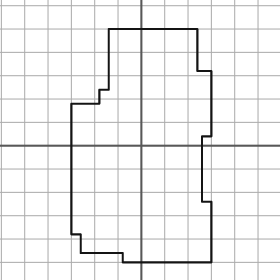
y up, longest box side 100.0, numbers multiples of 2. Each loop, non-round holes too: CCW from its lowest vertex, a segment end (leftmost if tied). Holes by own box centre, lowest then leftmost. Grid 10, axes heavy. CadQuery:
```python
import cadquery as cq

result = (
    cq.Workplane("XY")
    .moveTo(-8.0, -50.0)
    .lineTo(30.0, -50.0)
    .lineTo(30.0, -24.0)
    .lineTo(26.0, -24.0)
    .lineTo(26.0, 4.0)
    .lineTo(30.0, 4.0)
    .lineTo(30.0, 32.0)
    .lineTo(24.0, 32.0)
    .lineTo(24.0, 50.0)
    .lineTo(-14.0, 50.0)
    .lineTo(-14.0, 24.0)
    .lineTo(-18.0, 24.0)
    .lineTo(-18.0, 18.0)
    .lineTo(-30.0, 18.0)
    .lineTo(-30.0, -38.0)
    .lineTo(-26.0, -38.0)
    .lineTo(-26.0, -46.0)
    .lineTo(-8.0, -46.0)
    .close()
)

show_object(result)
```